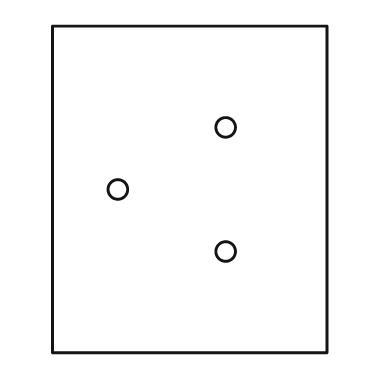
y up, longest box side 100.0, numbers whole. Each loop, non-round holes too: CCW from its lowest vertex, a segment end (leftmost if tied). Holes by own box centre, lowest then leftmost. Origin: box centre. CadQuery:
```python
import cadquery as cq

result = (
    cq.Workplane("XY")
    .moveTo(-42.0, -50.0)
    .lineTo(42.0, -50.0)
    .lineTo(42.0, 50.0)
    .lineTo(-42.0, 50.0)
    .close()
    .moveTo(11.0, -19.0)
    .circle(3.0)
    .moveTo(-22.0, 0.0)
    .circle(3.0)
    .moveTo(11.0, 19.0)
    .circle(3.0)
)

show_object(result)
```